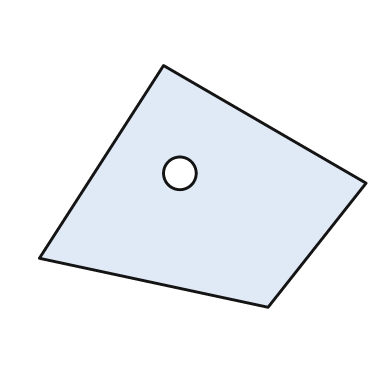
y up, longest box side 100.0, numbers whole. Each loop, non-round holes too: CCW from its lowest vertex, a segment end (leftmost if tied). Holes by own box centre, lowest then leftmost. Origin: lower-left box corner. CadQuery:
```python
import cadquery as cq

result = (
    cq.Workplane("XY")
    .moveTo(70.0, 0.0)
    .lineTo(100.0, 38.0)
    .lineTo(38.0, 74.0)
    .lineTo(0.0, 15.0)
    .close()
    .moveTo(43.0, 41.0)
    .circle(5.0)
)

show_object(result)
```